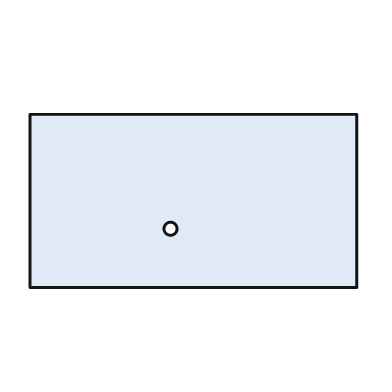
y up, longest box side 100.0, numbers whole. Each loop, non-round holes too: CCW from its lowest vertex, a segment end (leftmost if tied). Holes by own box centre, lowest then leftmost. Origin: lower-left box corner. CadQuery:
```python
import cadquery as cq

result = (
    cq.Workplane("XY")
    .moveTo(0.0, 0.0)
    .lineTo(100.0, 0.0)
    .lineTo(100.0, 53.0)
    .lineTo(0.0, 53.0)
    .close()
    .moveTo(43.0, 18.0)
    .circle(2.0)
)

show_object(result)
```